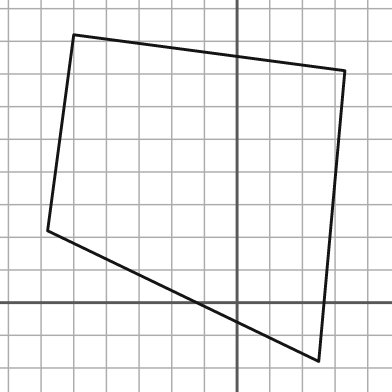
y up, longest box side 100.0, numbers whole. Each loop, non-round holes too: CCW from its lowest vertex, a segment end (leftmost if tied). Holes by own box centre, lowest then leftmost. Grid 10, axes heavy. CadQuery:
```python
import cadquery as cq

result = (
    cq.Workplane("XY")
    .moveTo(25.0, -18.0)
    .lineTo(33.0, 71.0)
    .lineTo(-50.0, 82.0)
    .lineTo(-58.0, 22.0)
    .close()
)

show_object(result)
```